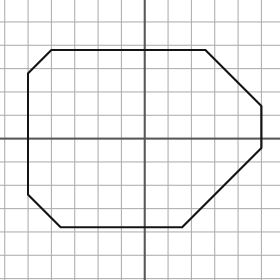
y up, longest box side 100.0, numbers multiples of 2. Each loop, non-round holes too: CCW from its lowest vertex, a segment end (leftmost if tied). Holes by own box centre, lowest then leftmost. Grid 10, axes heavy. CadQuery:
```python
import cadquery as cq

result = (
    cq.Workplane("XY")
    .moveTo(-36.0, -38.0)
    .lineTo(16.0, -38.0)
    .lineTo(50.0, -4.0)
    .lineTo(50.0, 14.0)
    .lineTo(26.0, 38.0)
    .lineTo(-40.0, 38.0)
    .lineTo(-50.0, 28.0)
    .lineTo(-50.0, -24.0)
    .close()
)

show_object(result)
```